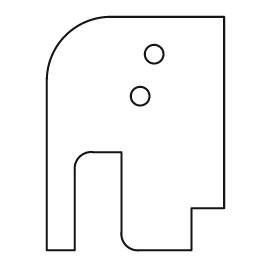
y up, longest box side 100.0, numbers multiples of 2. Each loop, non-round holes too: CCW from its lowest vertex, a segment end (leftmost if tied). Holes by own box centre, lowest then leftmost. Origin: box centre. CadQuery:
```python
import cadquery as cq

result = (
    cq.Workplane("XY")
    .moveTo(-38.0, -50.0)
    .lineTo(-26.0, -50.0)
    .lineTo(-26.0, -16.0)
    .threePointArc((-24.0, -10.0), (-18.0, -8.0))
    .lineTo(-6.0, -8.0)
    .lineTo(-6.0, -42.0)
    .threePointArc((-4.0, -48.0), (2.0, -50.0))
    .lineTo(24.0, -50.0)
    .lineTo(24.0, -32.0)
    .lineTo(38.0, -32.0)
    .lineTo(38.0, 50.0)
    .lineTo(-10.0, 50.0)
    .threePointArc((-30.0, 42.0), (-38.0, 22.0))
    .close()
    .moveTo(2.0, 16.0)
    .circle(4.0)
    .moveTo(8.0, 34.0)
    .circle(4.0)
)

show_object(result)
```